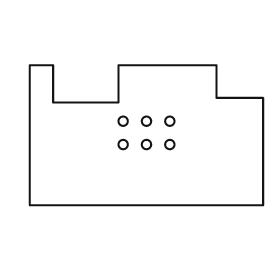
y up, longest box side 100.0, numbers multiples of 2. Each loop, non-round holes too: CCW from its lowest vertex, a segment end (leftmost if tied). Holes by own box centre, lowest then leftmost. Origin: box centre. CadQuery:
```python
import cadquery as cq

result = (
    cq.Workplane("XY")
    .moveTo(-50.0, -30.0)
    .lineTo(50.0, -30.0)
    .lineTo(50.0, 16.0)
    .lineTo(30.0, 16.0)
    .lineTo(30.0, 30.0)
    .lineTo(-12.0, 30.0)
    .lineTo(-12.0, 14.0)
    .lineTo(-40.0, 14.0)
    .lineTo(-40.0, 30.0)
    .lineTo(-50.0, 30.0)
    .close()
    .moveTo(-10.0, -4.0)
    .circle(2.0)
    .moveTo(0.0, -4.0)
    .circle(2.0)
    .moveTo(10.0, -4.0)
    .circle(2.0)
    .moveTo(-10.0, 6.0)
    .circle(2.0)
    .moveTo(0.0, 6.0)
    .circle(2.0)
    .moveTo(10.0, 6.0)
    .circle(2.0)
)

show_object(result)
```